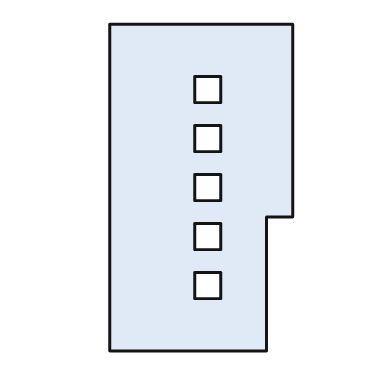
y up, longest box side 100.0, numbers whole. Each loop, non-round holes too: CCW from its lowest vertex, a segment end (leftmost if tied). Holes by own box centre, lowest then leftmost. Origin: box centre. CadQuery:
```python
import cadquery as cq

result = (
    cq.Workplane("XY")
    .moveTo(-28.0, -50.0)
    .lineTo(20.0, -50.0)
    .lineTo(20.0, -9.0)
    .lineTo(28.0, -9.0)
    .lineTo(28.0, 50.0)
    .lineTo(-28.0, 50.0)
    .close()
    .moveTo(-2.0, -34.0)
    .lineTo(6.0, -34.0)
    .lineTo(6.0, -26.0)
    .lineTo(-2.0, -26.0)
    .close()
    .moveTo(-2.0, -19.0)
    .lineTo(6.0, -19.0)
    .lineTo(6.0, -11.0)
    .lineTo(-2.0, -11.0)
    .close()
    .moveTo(-2.0, -4.0)
    .lineTo(6.0, -4.0)
    .lineTo(6.0, 4.0)
    .lineTo(-2.0, 4.0)
    .close()
    .moveTo(-2.0, 11.0)
    .lineTo(6.0, 11.0)
    .lineTo(6.0, 19.0)
    .lineTo(-2.0, 19.0)
    .close()
    .moveTo(-2.0, 26.0)
    .lineTo(6.0, 26.0)
    .lineTo(6.0, 34.0)
    .lineTo(-2.0, 34.0)
    .close()
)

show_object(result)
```